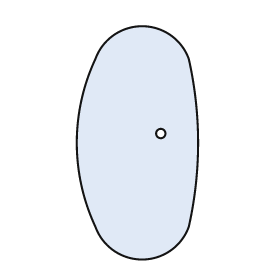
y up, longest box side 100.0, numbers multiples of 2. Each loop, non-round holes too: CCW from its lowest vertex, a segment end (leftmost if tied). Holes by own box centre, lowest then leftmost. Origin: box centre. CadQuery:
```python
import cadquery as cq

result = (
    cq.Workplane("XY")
    .moveTo(-18.0, -36.0)
    .threePointArc((2.0, -50.0), (22.0, -36.0))
    .threePointArc((26.0, 0.0), (22.0, 36.0))
    .threePointArc((2.0, 50.0), (-18.0, 36.0))
    .threePointArc((-26.0, 0.0), (-18.0, -36.0))
    .close()
    .moveTo(10.0, 4.0)
    .circle(2.0)
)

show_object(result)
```